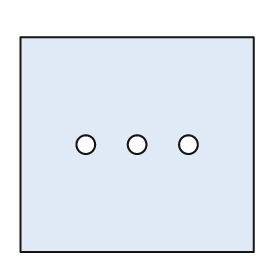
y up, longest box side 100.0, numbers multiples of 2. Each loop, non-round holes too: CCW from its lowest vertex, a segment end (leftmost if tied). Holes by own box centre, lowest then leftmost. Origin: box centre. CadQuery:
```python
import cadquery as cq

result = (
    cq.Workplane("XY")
    .moveTo(-50.0, -46.0)
    .lineTo(50.0, -46.0)
    .lineTo(50.0, 46.0)
    .lineTo(-50.0, 46.0)
    .close()
    .moveTo(-22.0, 0.0)
    .circle(4.0)
    .moveTo(0.0, 0.0)
    .circle(4.0)
    .moveTo(22.0, 0.0)
    .circle(4.0)
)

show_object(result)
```